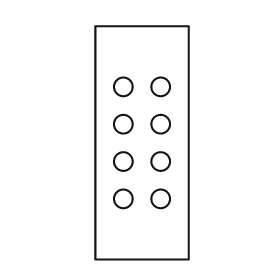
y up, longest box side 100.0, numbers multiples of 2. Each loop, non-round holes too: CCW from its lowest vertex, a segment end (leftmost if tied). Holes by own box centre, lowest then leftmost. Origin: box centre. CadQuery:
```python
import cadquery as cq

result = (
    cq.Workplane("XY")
    .moveTo(-20.0, -50.0)
    .lineTo(20.0, -50.0)
    .lineTo(20.0, 50.0)
    .lineTo(-20.0, 50.0)
    .close()
    .moveTo(-8.0, -24.0)
    .circle(4.0)
    .moveTo(8.0, -24.0)
    .circle(4.0)
    .moveTo(-8.0, -8.0)
    .circle(4.0)
    .moveTo(8.0, -8.0)
    .circle(4.0)
    .moveTo(-8.0, 8.0)
    .circle(4.0)
    .moveTo(8.0, 8.0)
    .circle(4.0)
    .moveTo(-8.0, 24.0)
    .circle(4.0)
    .moveTo(8.0, 24.0)
    .circle(4.0)
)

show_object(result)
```